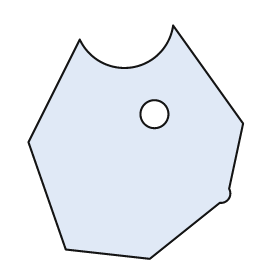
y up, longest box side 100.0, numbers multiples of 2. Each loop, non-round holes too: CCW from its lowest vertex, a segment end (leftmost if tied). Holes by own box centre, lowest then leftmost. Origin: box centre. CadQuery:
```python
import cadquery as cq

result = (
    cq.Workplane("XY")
    .moveTo(6.0, -50.0)
    .lineTo(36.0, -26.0)
    .threePointArc((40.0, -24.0), (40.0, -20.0))
    .lineTo(46.0, 8.0)
    .lineTo(16.0, 50.0)
    .threePointArc((-2.0, 32.0), (-24.0, 44.0))
    .lineTo(-46.0, 0.0)
    .lineTo(-30.0, -46.0)
    .close()
    .moveTo(8.0, 12.0)
    .circle(6.0)
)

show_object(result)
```